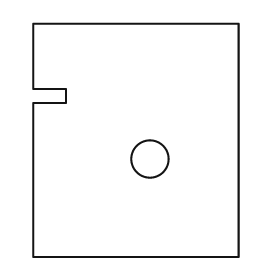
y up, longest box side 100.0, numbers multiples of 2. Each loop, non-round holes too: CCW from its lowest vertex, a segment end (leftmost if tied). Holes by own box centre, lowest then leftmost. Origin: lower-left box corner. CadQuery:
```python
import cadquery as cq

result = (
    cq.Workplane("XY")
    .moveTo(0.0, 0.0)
    .lineTo(88.0, 0.0)
    .lineTo(88.0, 100.0)
    .lineTo(0.0, 100.0)
    .lineTo(0.0, 72.0)
    .lineTo(14.0, 72.0)
    .lineTo(14.0, 66.0)
    .lineTo(0.0, 66.0)
    .close()
    .moveTo(50.0, 42.0)
    .circle(8.0)
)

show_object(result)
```